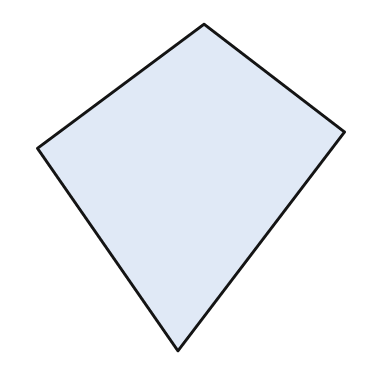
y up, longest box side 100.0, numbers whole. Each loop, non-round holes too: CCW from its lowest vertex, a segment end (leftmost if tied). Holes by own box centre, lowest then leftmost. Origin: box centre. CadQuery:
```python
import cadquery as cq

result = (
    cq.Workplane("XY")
    .moveTo(-4.0, -50.0)
    .lineTo(47.0, 17.0)
    .lineTo(4.0, 50.0)
    .lineTo(-47.0, 12.0)
    .close()
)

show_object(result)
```